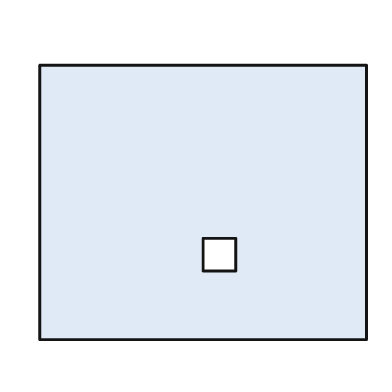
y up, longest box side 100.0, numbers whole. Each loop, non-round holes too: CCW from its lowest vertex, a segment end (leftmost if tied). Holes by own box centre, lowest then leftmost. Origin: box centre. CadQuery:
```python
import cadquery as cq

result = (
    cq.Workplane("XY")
    .moveTo(-50.0, -42.0)
    .lineTo(50.0, -42.0)
    .lineTo(50.0, 42.0)
    .lineTo(-50.0, 42.0)
    .close()
    .moveTo(0.0, -21.0)
    .lineTo(10.0, -21.0)
    .lineTo(10.0, -11.0)
    .lineTo(0.0, -11.0)
    .close()
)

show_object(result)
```